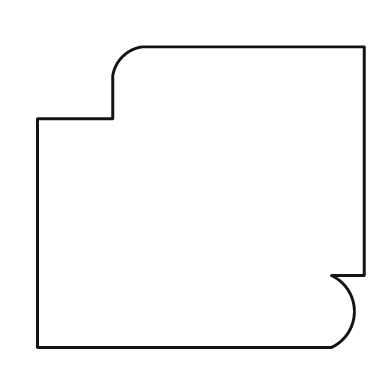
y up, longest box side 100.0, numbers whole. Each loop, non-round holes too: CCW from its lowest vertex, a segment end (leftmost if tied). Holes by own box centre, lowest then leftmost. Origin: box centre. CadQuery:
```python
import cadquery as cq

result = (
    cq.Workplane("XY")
    .moveTo(-50.0, -46.0)
    .lineTo(40.0, -46.0)
    .threePointArc((47.0, -35.0), (40.0, -24.0))
    .lineTo(50.0, -24.0)
    .lineTo(50.0, 46.0)
    .lineTo(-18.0, 46.0)
    .threePointArc((-24.0, 43.0), (-27.0, 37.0))
    .lineTo(-27.0, 24.0)
    .lineTo(-50.0, 24.0)
    .close()
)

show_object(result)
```